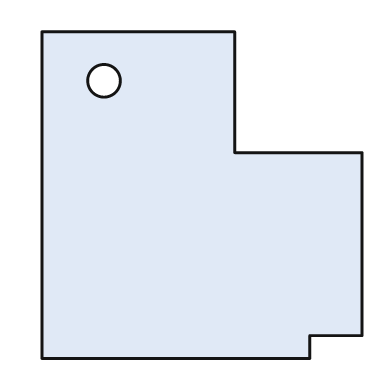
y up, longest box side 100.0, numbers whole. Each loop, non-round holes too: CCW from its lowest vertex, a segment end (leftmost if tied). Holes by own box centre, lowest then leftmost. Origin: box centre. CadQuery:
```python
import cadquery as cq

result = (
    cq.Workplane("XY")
    .moveTo(-49.0, -50.0)
    .lineTo(33.0, -50.0)
    .lineTo(33.0, -43.0)
    .lineTo(49.0, -43.0)
    .lineTo(49.0, 13.0)
    .lineTo(10.0, 13.0)
    .lineTo(10.0, 50.0)
    .lineTo(-49.0, 50.0)
    .close()
    .moveTo(-30.0, 35.0)
    .circle(5.0)
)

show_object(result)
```